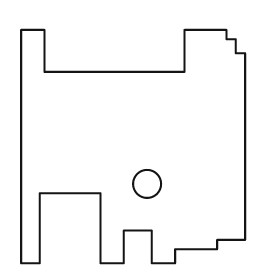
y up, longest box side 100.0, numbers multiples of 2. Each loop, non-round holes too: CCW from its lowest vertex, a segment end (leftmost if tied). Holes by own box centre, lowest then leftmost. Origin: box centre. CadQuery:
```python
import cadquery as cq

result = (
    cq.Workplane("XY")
    .moveTo(-48.0, -50.0)
    .lineTo(-40.0, -50.0)
    .lineTo(-40.0, -20.0)
    .lineTo(-14.0, -20.0)
    .lineTo(-14.0, -50.0)
    .lineTo(-4.0, -50.0)
    .lineTo(-4.0, -36.0)
    .lineTo(8.0, -36.0)
    .lineTo(8.0, -50.0)
    .lineTo(18.0, -50.0)
    .lineTo(18.0, -44.0)
    .lineTo(36.0, -44.0)
    .lineTo(36.0, -40.0)
    .lineTo(48.0, -40.0)
    .lineTo(48.0, 40.0)
    .lineTo(44.0, 40.0)
    .lineTo(44.0, 46.0)
    .lineTo(40.0, 46.0)
    .lineTo(40.0, 50.0)
    .lineTo(22.0, 50.0)
    .lineTo(22.0, 32.0)
    .lineTo(-38.0, 32.0)
    .lineTo(-38.0, 50.0)
    .lineTo(-48.0, 50.0)
    .close()
    .moveTo(6.0, -16.0)
    .circle(6.0)
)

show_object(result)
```